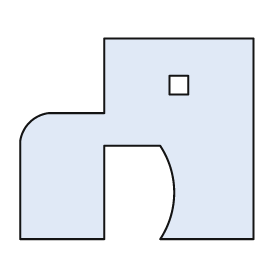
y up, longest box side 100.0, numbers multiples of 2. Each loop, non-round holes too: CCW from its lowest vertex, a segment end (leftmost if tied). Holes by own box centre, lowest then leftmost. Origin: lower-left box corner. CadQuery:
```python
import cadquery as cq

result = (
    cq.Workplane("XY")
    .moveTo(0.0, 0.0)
    .lineTo(36.0, 0.0)
    .lineTo(36.0, 40.0)
    .lineTo(60.0, 40.0)
    .threePointArc((66.0, 20.0), (60.0, 0.0))
    .lineTo(100.0, 0.0)
    .lineTo(100.0, 86.0)
    .lineTo(36.0, 86.0)
    .lineTo(36.0, 54.0)
    .lineTo(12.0, 54.0)
    .threePointArc((4.0, 50.0), (0.0, 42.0))
    .close()
    .moveTo(64.0, 62.0)
    .lineTo(72.0, 62.0)
    .lineTo(72.0, 70.0)
    .lineTo(64.0, 70.0)
    .close()
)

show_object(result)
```